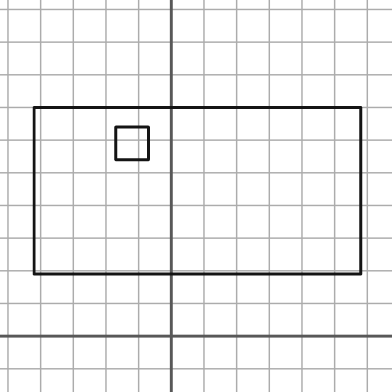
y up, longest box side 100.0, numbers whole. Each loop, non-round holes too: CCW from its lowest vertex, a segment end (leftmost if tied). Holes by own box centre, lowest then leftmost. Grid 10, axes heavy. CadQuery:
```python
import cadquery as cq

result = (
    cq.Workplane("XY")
    .moveTo(-42.0, 19.0)
    .lineTo(58.0, 19.0)
    .lineTo(58.0, 70.0)
    .lineTo(-42.0, 70.0)
    .close()
    .moveTo(-17.0, 54.0)
    .lineTo(-7.0, 54.0)
    .lineTo(-7.0, 64.0)
    .lineTo(-17.0, 64.0)
    .close()
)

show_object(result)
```